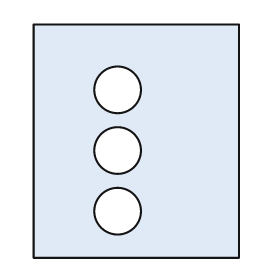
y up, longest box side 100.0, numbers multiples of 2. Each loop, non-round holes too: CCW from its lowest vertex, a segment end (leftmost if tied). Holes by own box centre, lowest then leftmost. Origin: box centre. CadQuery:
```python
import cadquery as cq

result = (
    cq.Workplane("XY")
    .moveTo(-44.0, -50.0)
    .lineTo(44.0, -50.0)
    .lineTo(44.0, 50.0)
    .lineTo(-44.0, 50.0)
    .close()
    .moveTo(-8.0, -30.0)
    .circle(10.0)
    .moveTo(-8.0, -4.0)
    .circle(10.0)
    .moveTo(-8.0, 22.0)
    .circle(10.0)
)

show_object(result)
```